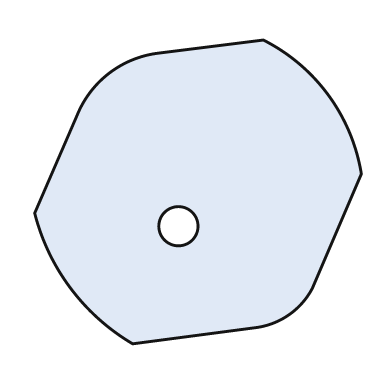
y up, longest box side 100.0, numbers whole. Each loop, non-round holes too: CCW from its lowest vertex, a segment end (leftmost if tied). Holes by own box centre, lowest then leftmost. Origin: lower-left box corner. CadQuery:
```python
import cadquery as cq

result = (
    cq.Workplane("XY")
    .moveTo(30.0, 0.0)
    .lineTo(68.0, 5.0)
    .threePointArc((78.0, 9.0), (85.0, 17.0))
    .lineTo(100.0, 52.0)
    .threePointArc((90.0, 76.0), (70.0, 93.0))
    .lineTo(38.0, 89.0)
    .threePointArc((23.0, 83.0), (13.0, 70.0))
    .lineTo(0.0, 40.0)
    .threePointArc((11.0, 17.0), (30.0, 0.0))
    .close()
    .moveTo(44.0, 36.0)
    .circle(6.0)
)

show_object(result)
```